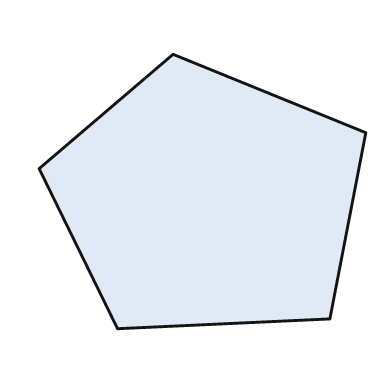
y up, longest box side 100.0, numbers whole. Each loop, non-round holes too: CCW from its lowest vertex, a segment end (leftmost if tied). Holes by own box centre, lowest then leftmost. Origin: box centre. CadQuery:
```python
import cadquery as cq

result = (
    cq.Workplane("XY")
    .moveTo(-26.0, -42.0)
    .lineTo(39.0, -39.0)
    .lineTo(50.0, 18.0)
    .lineTo(-9.0, 42.0)
    .lineTo(-50.0, 7.0)
    .close()
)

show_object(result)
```